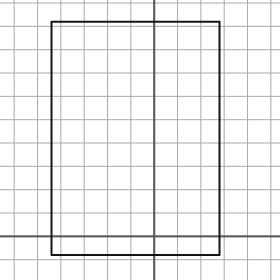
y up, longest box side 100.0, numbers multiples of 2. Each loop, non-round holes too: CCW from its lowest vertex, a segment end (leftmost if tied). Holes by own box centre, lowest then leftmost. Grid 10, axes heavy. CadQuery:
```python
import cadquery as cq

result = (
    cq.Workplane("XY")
    .moveTo(-44.0, -8.0)
    .lineTo(28.0, -8.0)
    .lineTo(28.0, 92.0)
    .lineTo(-44.0, 92.0)
    .close()
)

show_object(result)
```